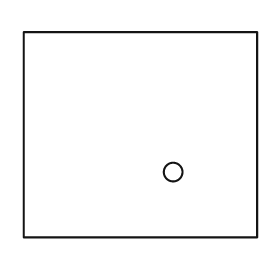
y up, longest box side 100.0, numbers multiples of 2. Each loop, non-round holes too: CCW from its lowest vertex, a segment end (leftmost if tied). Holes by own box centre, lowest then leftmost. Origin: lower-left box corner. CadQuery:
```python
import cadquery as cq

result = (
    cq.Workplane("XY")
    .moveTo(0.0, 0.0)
    .lineTo(100.0, 0.0)
    .lineTo(100.0, 88.0)
    .lineTo(0.0, 88.0)
    .close()
    .moveTo(64.0, 28.0)
    .circle(4.0)
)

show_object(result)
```